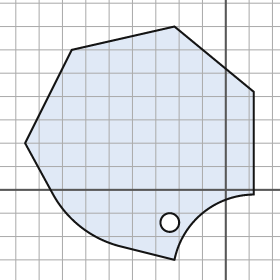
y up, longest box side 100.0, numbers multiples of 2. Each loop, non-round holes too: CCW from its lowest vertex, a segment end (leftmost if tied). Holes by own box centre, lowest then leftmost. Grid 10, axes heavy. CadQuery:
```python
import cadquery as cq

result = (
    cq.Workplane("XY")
    .moveTo(-22.0, -30.0)
    .threePointArc((-10.0, -10.0), (12.0, -2.0))
    .lineTo(12.0, 42.0)
    .lineTo(-22.0, 70.0)
    .lineTo(-66.0, 60.0)
    .lineTo(-86.0, 20.0)
    .lineTo(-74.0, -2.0)
    .threePointArc((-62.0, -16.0), (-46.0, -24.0))
    .close()
    .moveTo(-24.0, -14.0)
    .circle(4.0)
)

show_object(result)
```